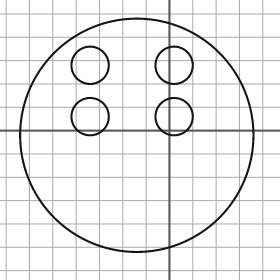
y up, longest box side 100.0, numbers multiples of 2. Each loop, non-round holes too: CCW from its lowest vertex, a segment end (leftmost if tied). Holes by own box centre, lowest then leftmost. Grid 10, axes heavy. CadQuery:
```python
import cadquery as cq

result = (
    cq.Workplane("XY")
    .moveTo(-14.0, -2.0)
    .circle(50.0)
    .moveTo(-34.0, 6.0)
    .circle(8.0)
    .moveTo(2.0, 6.0)
    .circle(8.0)
    .moveTo(-34.0, 28.0)
    .circle(8.0)
    .moveTo(2.0, 28.0)
    .circle(8.0)
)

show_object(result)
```